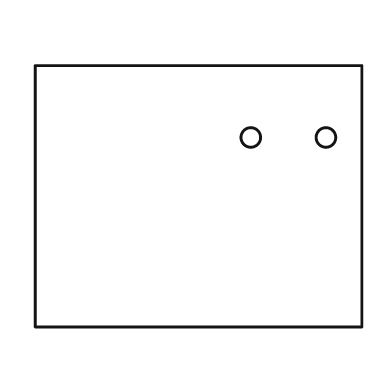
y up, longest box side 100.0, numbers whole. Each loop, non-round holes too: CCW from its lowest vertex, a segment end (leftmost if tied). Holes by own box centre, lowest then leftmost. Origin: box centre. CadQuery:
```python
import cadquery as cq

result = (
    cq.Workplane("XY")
    .moveTo(-50.0, -40.0)
    .lineTo(50.0, -40.0)
    .lineTo(50.0, 40.0)
    .lineTo(-50.0, 40.0)
    .close()
    .moveTo(16.0, 18.0)
    .circle(3.0)
    .moveTo(39.0, 18.0)
    .circle(3.0)
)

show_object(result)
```